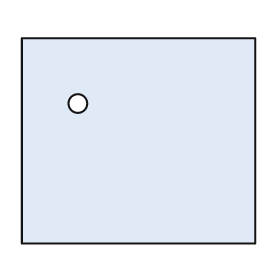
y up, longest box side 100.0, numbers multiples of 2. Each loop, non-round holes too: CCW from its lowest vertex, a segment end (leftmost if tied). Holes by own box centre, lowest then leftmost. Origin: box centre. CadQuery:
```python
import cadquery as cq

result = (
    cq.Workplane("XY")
    .moveTo(-50.0, -44.0)
    .lineTo(50.0, -44.0)
    .lineTo(50.0, 44.0)
    .lineTo(-50.0, 44.0)
    .close()
    .moveTo(-26.0, 16.0)
    .circle(4.0)
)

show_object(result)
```